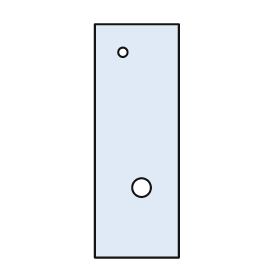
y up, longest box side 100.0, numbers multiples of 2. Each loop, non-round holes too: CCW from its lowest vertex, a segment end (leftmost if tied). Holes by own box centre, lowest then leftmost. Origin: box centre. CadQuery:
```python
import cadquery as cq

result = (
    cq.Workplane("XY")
    .moveTo(-18.0, -50.0)
    .lineTo(18.0, -50.0)
    .lineTo(18.0, 50.0)
    .lineTo(-18.0, 50.0)
    .close()
    .moveTo(2.0, -20.0)
    .circle(4.0)
    .moveTo(-6.0, 38.0)
    .circle(2.0)
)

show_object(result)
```